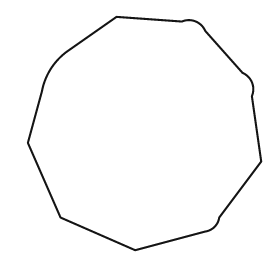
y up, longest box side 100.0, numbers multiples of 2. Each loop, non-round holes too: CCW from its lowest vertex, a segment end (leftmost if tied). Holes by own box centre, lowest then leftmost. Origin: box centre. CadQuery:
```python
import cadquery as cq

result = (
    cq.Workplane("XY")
    .moveTo(-4.0, -50.0)
    .lineTo(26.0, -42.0)
    .threePointArc((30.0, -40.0), (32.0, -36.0))
    .lineTo(50.0, -12.0)
    .lineTo(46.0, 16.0)
    .threePointArc((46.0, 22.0), (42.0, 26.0))
    .lineTo(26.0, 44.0)
    .threePointArc((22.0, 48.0), (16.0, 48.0))
    .lineTo(-12.0, 50.0)
    .lineTo(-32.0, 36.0)
    .threePointArc((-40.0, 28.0), (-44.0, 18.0))
    .lineTo(-50.0, -4.0)
    .lineTo(-36.0, -36.0)
    .close()
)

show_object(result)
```